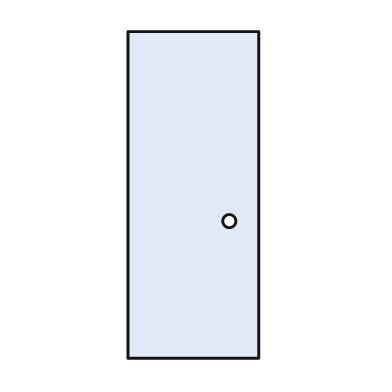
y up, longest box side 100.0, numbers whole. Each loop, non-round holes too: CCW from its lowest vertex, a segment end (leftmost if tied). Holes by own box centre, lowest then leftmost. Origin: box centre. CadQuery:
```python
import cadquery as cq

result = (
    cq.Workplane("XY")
    .moveTo(-20.0, -50.0)
    .lineTo(20.0, -50.0)
    .lineTo(20.0, 50.0)
    .lineTo(-20.0, 50.0)
    .close()
    .moveTo(11.0, -8.0)
    .circle(2.0)
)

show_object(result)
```